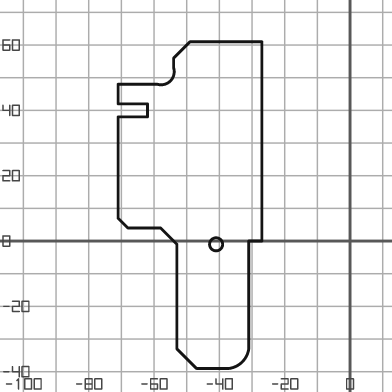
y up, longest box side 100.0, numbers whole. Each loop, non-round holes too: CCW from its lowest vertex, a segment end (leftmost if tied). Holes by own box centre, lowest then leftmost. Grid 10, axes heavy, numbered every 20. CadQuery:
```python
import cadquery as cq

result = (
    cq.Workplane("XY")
    .moveTo(-47.0, -39.0)
    .lineTo(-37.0, -39.0)
    .threePointArc((-33.0, -37.0), (-31.0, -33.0))
    .lineTo(-31.0, 0.0)
    .lineTo(-27.0, 0.0)
    .lineTo(-27.0, 61.0)
    .lineTo(-49.0, 61.0)
    .lineTo(-54.0, 56.0)
    .lineTo(-54.0, 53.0)
    .threePointArc((-55.0, 49.0), (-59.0, 48.0))
    .lineTo(-71.0, 48.0)
    .lineTo(-71.0, 42.0)
    .lineTo(-62.0, 42.0)
    .lineTo(-62.0, 38.0)
    .lineTo(-71.0, 38.0)
    .lineTo(-71.0, 7.0)
    .lineTo(-68.0, 4.0)
    .lineTo(-58.0, 4.0)
    .lineTo(-53.0, -1.0)
    .lineTo(-53.0, -33.0)
    .close()
    .moveTo(-41.0, -1.0)
    .circle(2.0)
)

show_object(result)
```